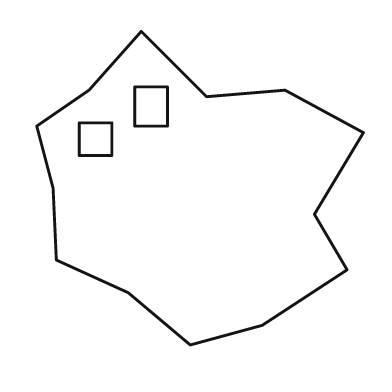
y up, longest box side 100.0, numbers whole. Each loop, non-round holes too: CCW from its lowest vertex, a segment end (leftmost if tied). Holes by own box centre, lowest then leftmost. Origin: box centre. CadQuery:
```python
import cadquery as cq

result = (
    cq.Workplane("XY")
    .moveTo(-3.0, -48.0)
    .lineTo(19.0, -42.0)
    .lineTo(45.0, -25.0)
    .lineTo(35.0, -8.0)
    .lineTo(50.0, 17.0)
    .lineTo(26.0, 30.0)
    .lineTo(2.0, 28.0)
    .lineTo(-18.0, 48.0)
    .lineTo(-34.0, 30.0)
    .lineTo(-50.0, 19.0)
    .lineTo(-45.0, 0.0)
    .lineTo(-44.0, -22.0)
    .lineTo(-22.0, -32.0)
    .close()
    .moveTo(-37.0, 10.0)
    .lineTo(-27.0, 10.0)
    .lineTo(-27.0, 20.0)
    .lineTo(-37.0, 20.0)
    .close()
    .moveTo(-20.0, 19.0)
    .lineTo(-10.0, 19.0)
    .lineTo(-10.0, 31.0)
    .lineTo(-20.0, 31.0)
    .close()
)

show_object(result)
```